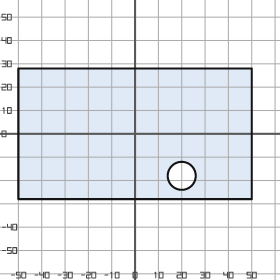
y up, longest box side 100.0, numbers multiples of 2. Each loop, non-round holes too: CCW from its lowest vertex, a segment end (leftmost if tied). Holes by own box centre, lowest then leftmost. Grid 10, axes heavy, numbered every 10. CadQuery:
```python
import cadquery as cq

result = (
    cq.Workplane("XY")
    .moveTo(-50.0, -28.0)
    .lineTo(50.0, -28.0)
    .lineTo(50.0, 28.0)
    .lineTo(-50.0, 28.0)
    .close()
    .moveTo(20.0, -18.0)
    .circle(6.0)
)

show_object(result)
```